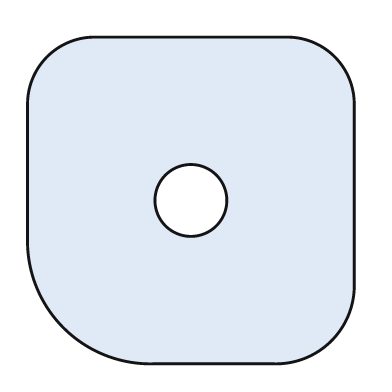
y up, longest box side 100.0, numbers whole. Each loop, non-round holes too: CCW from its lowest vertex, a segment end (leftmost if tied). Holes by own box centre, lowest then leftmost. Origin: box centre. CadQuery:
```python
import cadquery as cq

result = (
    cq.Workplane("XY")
    .moveTo(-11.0, -50.0)
    .lineTo(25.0, -50.0)
    .threePointArc((43.0, -43.0), (50.0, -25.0))
    .lineTo(50.0, 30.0)
    .threePointArc((44.0, 44.0), (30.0, 50.0))
    .lineTo(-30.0, 50.0)
    .threePointArc((-44.0, 44.0), (-50.0, 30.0))
    .lineTo(-50.0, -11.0)
    .threePointArc((-39.0, -39.0), (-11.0, -50.0))
    .close()
    .moveTo(0.0, 0.0)
    .circle(11.0)
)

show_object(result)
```